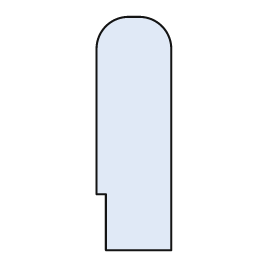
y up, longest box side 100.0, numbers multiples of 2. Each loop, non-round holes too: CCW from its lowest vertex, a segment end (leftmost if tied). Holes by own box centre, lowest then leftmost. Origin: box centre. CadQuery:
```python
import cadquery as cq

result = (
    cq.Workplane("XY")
    .moveTo(-12.0, -50.0)
    .lineTo(16.0, -50.0)
    .lineTo(16.0, 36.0)
    .threePointArc((12.0, 46.0), (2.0, 50.0))
    .lineTo(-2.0, 50.0)
    .threePointArc((-12.0, 46.0), (-16.0, 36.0))
    .lineTo(-16.0, -26.0)
    .lineTo(-12.0, -26.0)
    .close()
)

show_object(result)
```